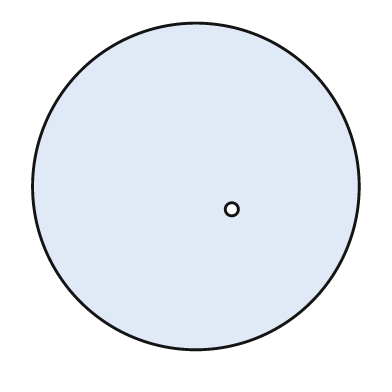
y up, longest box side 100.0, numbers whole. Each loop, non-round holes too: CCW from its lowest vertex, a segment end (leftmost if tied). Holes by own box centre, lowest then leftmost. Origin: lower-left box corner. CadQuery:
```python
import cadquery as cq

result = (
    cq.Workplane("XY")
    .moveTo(50.0, 50.0)
    .circle(50.0)
    .moveTo(61.0, 43.0)
    .circle(2.0)
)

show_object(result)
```